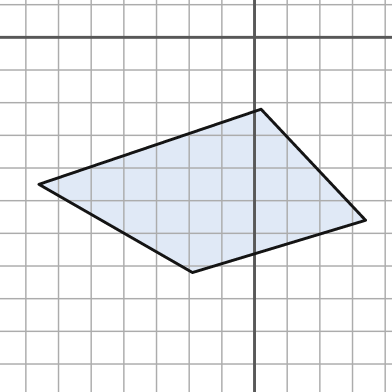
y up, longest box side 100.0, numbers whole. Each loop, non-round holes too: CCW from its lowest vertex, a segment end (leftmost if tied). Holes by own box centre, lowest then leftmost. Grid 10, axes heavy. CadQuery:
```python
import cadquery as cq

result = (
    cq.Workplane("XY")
    .moveTo(-19.0, -72.0)
    .lineTo(34.0, -56.0)
    .lineTo(2.0, -22.0)
    .lineTo(-66.0, -45.0)
    .close()
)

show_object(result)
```